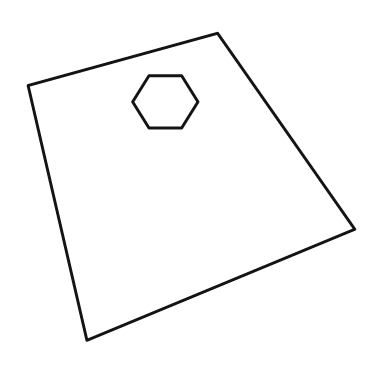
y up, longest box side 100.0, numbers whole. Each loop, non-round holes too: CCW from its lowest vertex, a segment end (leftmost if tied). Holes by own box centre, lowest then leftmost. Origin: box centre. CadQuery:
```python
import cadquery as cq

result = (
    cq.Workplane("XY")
    .moveTo(-32.0, -47.0)
    .lineTo(50.0, -13.0)
    .lineTo(8.0, 47.0)
    .lineTo(-50.0, 31.0)
    .close()
    .moveTo(-13.0, 18.0)
    .lineTo(-3.0, 18.0)
    .lineTo(2.0, 26.0)
    .lineTo(-3.0, 34.0)
    .lineTo(-13.0, 34.0)
    .lineTo(-18.0, 26.0)
    .close()
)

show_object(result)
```